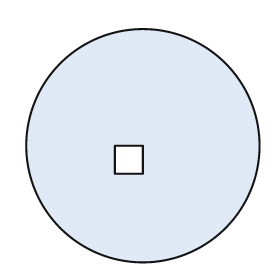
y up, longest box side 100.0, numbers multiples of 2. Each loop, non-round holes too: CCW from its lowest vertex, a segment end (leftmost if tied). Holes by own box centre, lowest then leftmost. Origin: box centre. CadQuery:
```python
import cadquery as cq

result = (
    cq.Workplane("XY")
    .moveTo(0.0, 0.0)
    .circle(50.0)
    .moveTo(-12.0, -12.0)
    .lineTo(0.0, -12.0)
    .lineTo(0.0, 0.0)
    .lineTo(-12.0, 0.0)
    .close()
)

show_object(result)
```